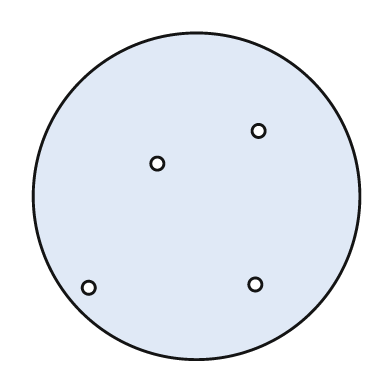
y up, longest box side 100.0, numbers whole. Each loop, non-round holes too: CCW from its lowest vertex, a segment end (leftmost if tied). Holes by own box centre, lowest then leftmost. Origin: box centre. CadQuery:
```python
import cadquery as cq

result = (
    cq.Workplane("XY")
    .moveTo(0.0, 0.0)
    .circle(50.0)
    .moveTo(-33.0, -28.0)
    .circle(2.0)
    .moveTo(18.0, -27.0)
    .circle(2.0)
    .moveTo(-12.0, 10.0)
    .circle(2.0)
    .moveTo(19.0, 20.0)
    .circle(2.0)
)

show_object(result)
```